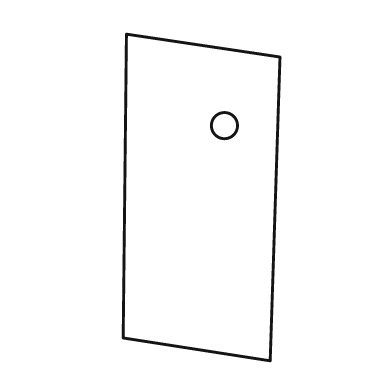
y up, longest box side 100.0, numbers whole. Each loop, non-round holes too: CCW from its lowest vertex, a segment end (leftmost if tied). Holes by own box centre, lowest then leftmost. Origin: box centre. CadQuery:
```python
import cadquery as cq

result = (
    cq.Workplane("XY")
    .moveTo(21.0, -50.0)
    .lineTo(24.0, 43.0)
    .lineTo(-23.0, 50.0)
    .lineTo(-24.0, -43.0)
    .close()
    .moveTo(7.0, 22.0)
    .circle(4.0)
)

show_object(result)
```